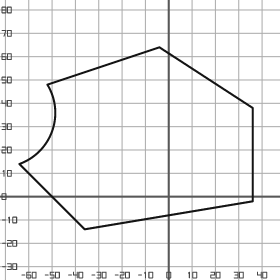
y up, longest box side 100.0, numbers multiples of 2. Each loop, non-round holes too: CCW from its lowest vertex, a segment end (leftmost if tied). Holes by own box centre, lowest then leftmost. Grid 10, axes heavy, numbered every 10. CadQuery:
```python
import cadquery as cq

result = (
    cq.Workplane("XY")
    .moveTo(-36.0, -14.0)
    .lineTo(36.0, -2.0)
    .lineTo(36.0, 38.0)
    .lineTo(-4.0, 64.0)
    .lineTo(-52.0, 48.0)
    .threePointArc((-50.0, 28.0), (-64.0, 14.0))
    .close()
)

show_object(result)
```